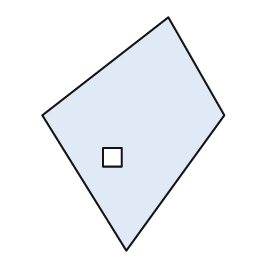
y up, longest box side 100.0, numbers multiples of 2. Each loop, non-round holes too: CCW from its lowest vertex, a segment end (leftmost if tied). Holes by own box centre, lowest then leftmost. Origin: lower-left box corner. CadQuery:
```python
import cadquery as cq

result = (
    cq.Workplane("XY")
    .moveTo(36.0, 0.0)
    .lineTo(78.0, 58.0)
    .lineTo(54.0, 100.0)
    .lineTo(0.0, 58.0)
    .close()
    .moveTo(26.0, 36.0)
    .lineTo(34.0, 36.0)
    .lineTo(34.0, 44.0)
    .lineTo(26.0, 44.0)
    .close()
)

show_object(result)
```